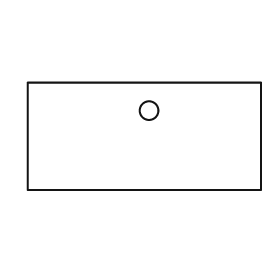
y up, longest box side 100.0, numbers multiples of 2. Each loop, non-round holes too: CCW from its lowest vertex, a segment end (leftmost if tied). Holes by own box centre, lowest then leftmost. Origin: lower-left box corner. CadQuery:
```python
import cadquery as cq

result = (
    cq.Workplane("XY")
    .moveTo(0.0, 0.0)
    .lineTo(100.0, 0.0)
    .lineTo(100.0, 46.0)
    .lineTo(0.0, 46.0)
    .close()
    .moveTo(52.0, 34.0)
    .circle(4.0)
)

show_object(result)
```